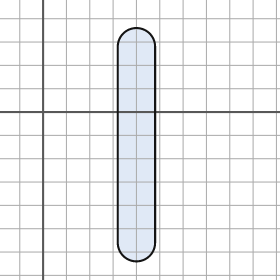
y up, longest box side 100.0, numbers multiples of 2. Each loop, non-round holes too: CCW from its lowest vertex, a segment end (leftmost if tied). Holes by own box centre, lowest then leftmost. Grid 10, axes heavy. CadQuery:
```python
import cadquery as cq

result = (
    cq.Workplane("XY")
    .moveTo(32.0, -56.0)
    .threePointArc((40.0, -64.0), (48.0, -56.0))
    .lineTo(48.0, 28.0)
    .threePointArc((40.0, 36.0), (32.0, 28.0))
    .close()
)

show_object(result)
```